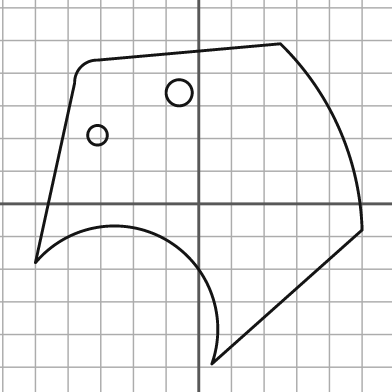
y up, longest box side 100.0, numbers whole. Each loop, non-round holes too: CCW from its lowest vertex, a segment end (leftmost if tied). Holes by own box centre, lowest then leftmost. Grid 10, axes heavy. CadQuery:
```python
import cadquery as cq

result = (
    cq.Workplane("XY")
    .moveTo(4.0, -49.0)
    .lineTo(50.0, -8.0)
    .threePointArc((43.0, 23.0), (25.0, 49.0))
    .lineTo(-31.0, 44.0)
    .threePointArc((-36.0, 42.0), (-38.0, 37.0))
    .lineTo(-50.0, -18.0)
    .threePointArc((-10.0, -11.0), (4.0, -49.0))
    .close()
    .moveTo(-31.0, 21.0)
    .circle(3.0)
    .moveTo(-6.0, 34.0)
    .circle(4.0)
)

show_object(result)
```